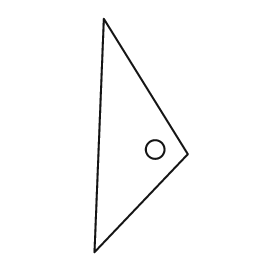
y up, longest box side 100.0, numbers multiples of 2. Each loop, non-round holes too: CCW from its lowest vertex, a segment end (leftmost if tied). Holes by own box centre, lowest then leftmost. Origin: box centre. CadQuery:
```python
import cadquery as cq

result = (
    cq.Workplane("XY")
    .moveTo(-20.0, -50.0)
    .lineTo(20.0, -8.0)
    .lineTo(-16.0, 50.0)
    .close()
    .moveTo(6.0, -6.0)
    .circle(4.0)
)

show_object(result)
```